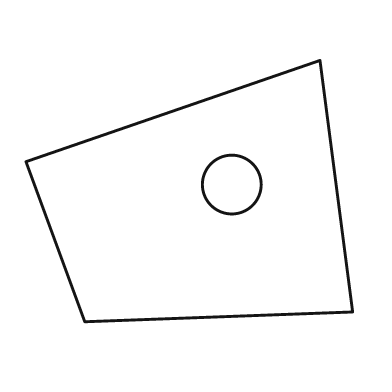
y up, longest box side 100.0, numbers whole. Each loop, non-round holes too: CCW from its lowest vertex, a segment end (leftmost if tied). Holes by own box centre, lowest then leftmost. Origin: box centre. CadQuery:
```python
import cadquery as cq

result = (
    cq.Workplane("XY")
    .moveTo(-32.0, -40.0)
    .lineTo(50.0, -37.0)
    .lineTo(40.0, 40.0)
    .lineTo(-50.0, 9.0)
    .close()
    .moveTo(13.0, 2.0)
    .circle(9.0)
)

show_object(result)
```